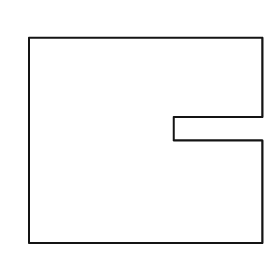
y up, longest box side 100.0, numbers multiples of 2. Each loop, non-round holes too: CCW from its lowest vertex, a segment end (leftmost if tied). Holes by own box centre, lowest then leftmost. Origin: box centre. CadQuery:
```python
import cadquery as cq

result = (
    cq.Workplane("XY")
    .moveTo(-50.0, -44.0)
    .lineTo(50.0, -44.0)
    .lineTo(50.0, 0.0)
    .lineTo(12.0, 0.0)
    .lineTo(12.0, 10.0)
    .lineTo(50.0, 10.0)
    .lineTo(50.0, 44.0)
    .lineTo(-50.0, 44.0)
    .close()
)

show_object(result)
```